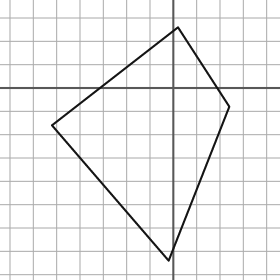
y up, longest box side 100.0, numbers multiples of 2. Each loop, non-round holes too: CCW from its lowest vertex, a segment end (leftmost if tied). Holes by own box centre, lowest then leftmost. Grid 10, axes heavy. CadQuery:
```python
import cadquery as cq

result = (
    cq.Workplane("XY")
    .moveTo(-2.0, -74.0)
    .lineTo(24.0, -8.0)
    .lineTo(2.0, 26.0)
    .lineTo(-52.0, -16.0)
    .close()
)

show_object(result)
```